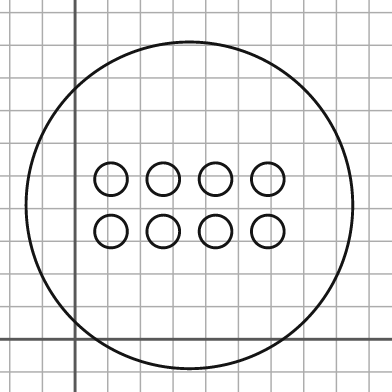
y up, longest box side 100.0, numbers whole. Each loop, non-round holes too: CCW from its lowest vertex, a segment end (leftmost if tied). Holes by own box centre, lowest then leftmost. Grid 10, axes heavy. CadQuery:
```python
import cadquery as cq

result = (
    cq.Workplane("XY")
    .moveTo(35.0, 41.0)
    .circle(50.0)
    .moveTo(11.0, 33.0)
    .circle(5.0)
    .moveTo(27.0, 33.0)
    .circle(5.0)
    .moveTo(43.0, 33.0)
    .circle(5.0)
    .moveTo(59.0, 33.0)
    .circle(5.0)
    .moveTo(11.0, 49.0)
    .circle(5.0)
    .moveTo(27.0, 49.0)
    .circle(5.0)
    .moveTo(43.0, 49.0)
    .circle(5.0)
    .moveTo(59.0, 49.0)
    .circle(5.0)
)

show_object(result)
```